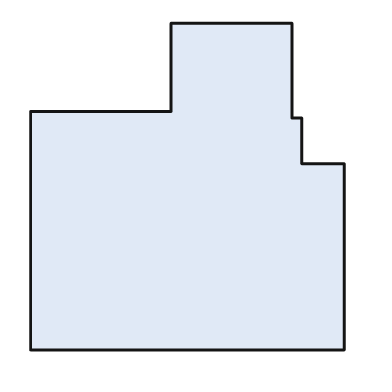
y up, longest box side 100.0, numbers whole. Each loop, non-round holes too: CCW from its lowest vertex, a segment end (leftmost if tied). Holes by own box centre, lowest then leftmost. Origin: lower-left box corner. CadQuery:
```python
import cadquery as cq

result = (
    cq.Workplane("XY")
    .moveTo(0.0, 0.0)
    .lineTo(96.0, 0.0)
    .lineTo(96.0, 57.0)
    .lineTo(83.0, 57.0)
    .lineTo(83.0, 71.0)
    .lineTo(80.0, 71.0)
    .lineTo(80.0, 100.0)
    .lineTo(43.0, 100.0)
    .lineTo(43.0, 73.0)
    .lineTo(0.0, 73.0)
    .close()
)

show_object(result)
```